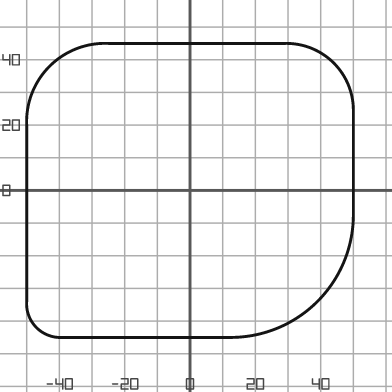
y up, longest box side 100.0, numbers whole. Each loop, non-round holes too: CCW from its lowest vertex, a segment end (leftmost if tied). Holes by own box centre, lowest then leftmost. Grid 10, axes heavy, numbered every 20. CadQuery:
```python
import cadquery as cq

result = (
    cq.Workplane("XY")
    .moveTo(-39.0, -45.0)
    .lineTo(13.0, -45.0)
    .threePointArc((39.0, -34.0), (50.0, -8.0))
    .lineTo(50.0, 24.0)
    .threePointArc((44.0, 39.0), (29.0, 45.0))
    .lineTo(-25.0, 45.0)
    .threePointArc((-43.0, 38.0), (-50.0, 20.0))
    .lineTo(-50.0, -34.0)
    .threePointArc((-47.0, -42.0), (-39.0, -45.0))
    .close()
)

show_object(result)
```